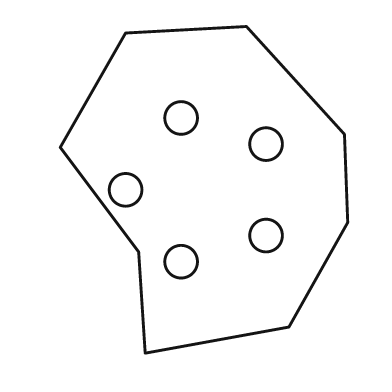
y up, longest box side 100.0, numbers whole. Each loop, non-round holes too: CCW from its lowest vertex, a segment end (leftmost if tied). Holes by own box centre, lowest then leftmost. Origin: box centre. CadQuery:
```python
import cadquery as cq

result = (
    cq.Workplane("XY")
    .moveTo(-18.0, -50.0)
    .lineTo(26.0, -42.0)
    .lineTo(44.0, -10.0)
    .lineTo(43.0, 17.0)
    .lineTo(13.0, 50.0)
    .lineTo(-24.0, 48.0)
    .lineTo(-44.0, 13.0)
    .lineTo(-20.0, -19.0)
    .close()
    .moveTo(-7.0, -22.0)
    .circle(5.0)
    .moveTo(19.0, -14.0)
    .circle(5.0)
    .moveTo(-24.0, 0.0)
    .circle(5.0)
    .moveTo(19.0, 14.0)
    .circle(5.0)
    .moveTo(-7.0, 22.0)
    .circle(5.0)
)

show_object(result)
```